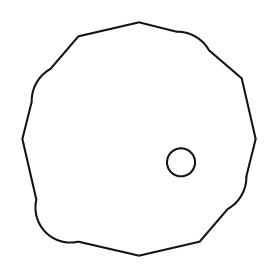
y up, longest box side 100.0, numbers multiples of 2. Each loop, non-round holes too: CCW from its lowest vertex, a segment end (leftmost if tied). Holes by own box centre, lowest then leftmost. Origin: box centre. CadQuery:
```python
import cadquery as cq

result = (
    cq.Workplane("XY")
    .moveTo(0.0, -50.0)
    .lineTo(26.0, -44.0)
    .lineTo(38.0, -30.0)
    .threePointArc((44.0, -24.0), (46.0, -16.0))
    .lineTo(50.0, 0.0)
    .lineTo(44.0, 26.0)
    .lineTo(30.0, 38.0)
    .threePointArc((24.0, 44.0), (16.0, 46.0))
    .lineTo(0.0, 50.0)
    .lineTo(-26.0, 44.0)
    .lineTo(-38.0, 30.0)
    .threePointArc((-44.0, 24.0), (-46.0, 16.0))
    .lineTo(-50.0, 0.0)
    .lineTo(-44.0, -26.0)
    .threePointArc((-40.0, -40.0), (-26.0, -44.0))
    .close()
    .moveTo(18.0, -10.0)
    .circle(6.0)
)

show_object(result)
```